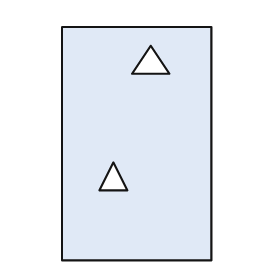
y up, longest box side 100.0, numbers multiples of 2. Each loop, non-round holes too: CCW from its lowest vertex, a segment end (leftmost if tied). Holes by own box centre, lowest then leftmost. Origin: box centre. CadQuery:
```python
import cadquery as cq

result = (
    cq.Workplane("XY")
    .moveTo(-32.0, -50.0)
    .lineTo(32.0, -50.0)
    .lineTo(32.0, 50.0)
    .lineTo(-32.0, 50.0)
    .close()
    .moveTo(-16.0, -20.0)
    .lineTo(-4.0, -20.0)
    .lineTo(-10.0, -8.0)
    .close()
    .moveTo(-2.0, 30.0)
    .lineTo(14.0, 30.0)
    .lineTo(6.0, 42.0)
    .close()
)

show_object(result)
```